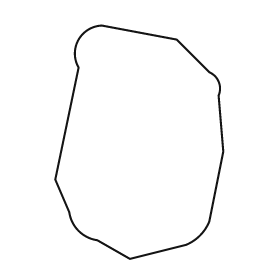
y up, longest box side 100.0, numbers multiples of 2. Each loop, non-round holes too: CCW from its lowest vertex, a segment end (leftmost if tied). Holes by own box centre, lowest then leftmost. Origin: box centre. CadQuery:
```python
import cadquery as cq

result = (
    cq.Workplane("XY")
    .moveTo(-4.0, -50.0)
    .lineTo(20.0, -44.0)
    .threePointArc((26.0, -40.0), (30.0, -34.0))
    .lineTo(36.0, -4.0)
    .lineTo(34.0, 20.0)
    .threePointArc((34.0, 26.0), (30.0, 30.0))
    .lineTo(16.0, 44.0)
    .lineTo(-16.0, 50.0)
    .threePointArc((-26.0, 44.0), (-26.0, 32.0))
    .lineTo(-36.0, -16.0)
    .lineTo(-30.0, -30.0)
    .threePointArc((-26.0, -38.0), (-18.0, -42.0))
    .close()
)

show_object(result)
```